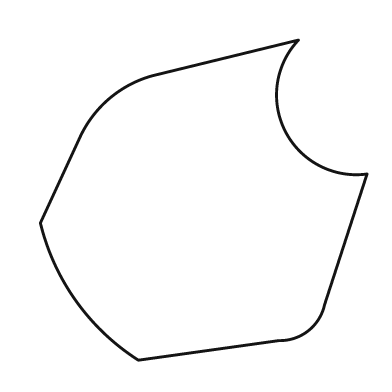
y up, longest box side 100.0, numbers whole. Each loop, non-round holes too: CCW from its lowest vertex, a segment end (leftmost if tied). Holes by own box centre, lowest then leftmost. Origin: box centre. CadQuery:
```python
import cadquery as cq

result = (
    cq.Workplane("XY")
    .moveTo(-20.0, -49.0)
    .lineTo(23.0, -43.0)
    .threePointArc((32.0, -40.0), (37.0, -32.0))
    .lineTo(50.0, 8.0)
    .threePointArc((25.0, 21.0), (29.0, 49.0))
    .lineTo(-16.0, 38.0)
    .threePointArc((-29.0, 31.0), (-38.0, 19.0))
    .lineTo(-50.0, -7.0)
    .threePointArc((-39.0, -31.0), (-20.0, -49.0))
    .close()
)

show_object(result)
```